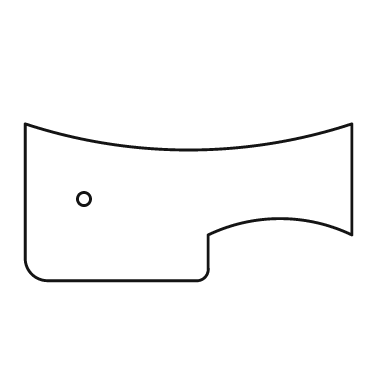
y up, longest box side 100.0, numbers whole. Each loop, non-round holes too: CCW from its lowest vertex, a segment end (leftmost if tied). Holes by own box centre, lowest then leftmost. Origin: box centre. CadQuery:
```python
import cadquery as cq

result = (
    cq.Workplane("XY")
    .moveTo(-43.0, -24.0)
    .lineTo(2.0, -24.0)
    .threePointArc((5.0, -23.0), (6.0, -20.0))
    .lineTo(6.0, -10.0)
    .threePointArc((28.0, -5.0), (50.0, -10.0))
    .lineTo(50.0, 24.0)
    .threePointArc((0.0, 16.0), (-50.0, 24.0))
    .lineTo(-50.0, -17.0)
    .threePointArc((-48.0, -22.0), (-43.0, -24.0))
    .close()
    .moveTo(-32.0, 1.0)
    .circle(2.0)
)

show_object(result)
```